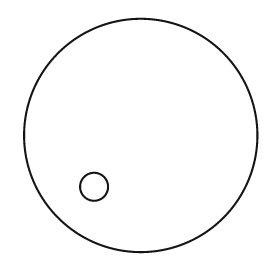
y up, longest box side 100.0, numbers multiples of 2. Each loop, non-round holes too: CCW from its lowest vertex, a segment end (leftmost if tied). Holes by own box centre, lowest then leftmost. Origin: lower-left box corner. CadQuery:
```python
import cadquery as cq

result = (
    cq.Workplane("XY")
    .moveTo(50.0, 50.0)
    .circle(50.0)
    .moveTo(30.0, 28.0)
    .circle(6.0)
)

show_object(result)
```